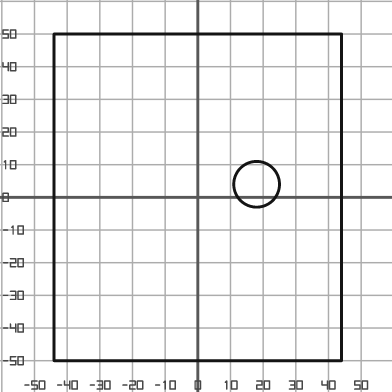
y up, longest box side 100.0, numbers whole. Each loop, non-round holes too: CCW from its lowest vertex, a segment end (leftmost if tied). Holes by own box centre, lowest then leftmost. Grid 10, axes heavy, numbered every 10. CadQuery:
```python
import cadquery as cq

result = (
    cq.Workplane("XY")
    .moveTo(-44.0, -50.0)
    .lineTo(44.0, -50.0)
    .lineTo(44.0, 50.0)
    .lineTo(-44.0, 50.0)
    .close()
    .moveTo(18.0, 4.0)
    .circle(7.0)
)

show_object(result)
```